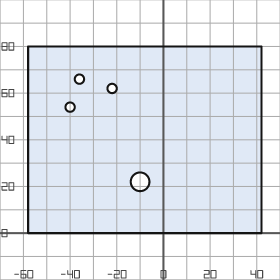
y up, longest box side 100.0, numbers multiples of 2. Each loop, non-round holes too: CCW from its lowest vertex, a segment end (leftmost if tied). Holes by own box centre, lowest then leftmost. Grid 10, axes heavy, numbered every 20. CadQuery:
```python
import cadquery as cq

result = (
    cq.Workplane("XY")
    .moveTo(-58.0, 0.0)
    .lineTo(42.0, 0.0)
    .lineTo(42.0, 80.0)
    .lineTo(-58.0, 80.0)
    .close()
    .moveTo(-10.0, 22.0)
    .circle(4.0)
    .moveTo(-40.0, 54.0)
    .circle(2.0)
    .moveTo(-22.0, 62.0)
    .circle(2.0)
    .moveTo(-36.0, 66.0)
    .circle(2.0)
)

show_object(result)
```